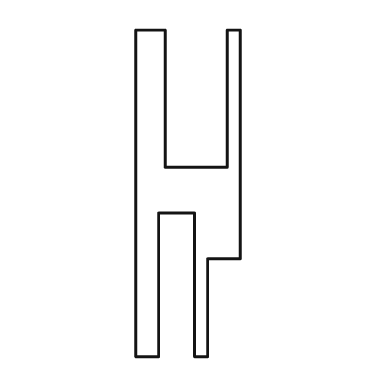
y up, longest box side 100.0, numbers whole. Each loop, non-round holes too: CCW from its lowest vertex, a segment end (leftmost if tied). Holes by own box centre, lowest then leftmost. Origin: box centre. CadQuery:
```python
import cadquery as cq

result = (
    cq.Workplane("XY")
    .moveTo(-16.0, -50.0)
    .lineTo(-9.0, -50.0)
    .lineTo(-9.0, -6.0)
    .lineTo(2.0, -6.0)
    .lineTo(2.0, -50.0)
    .lineTo(6.0, -50.0)
    .lineTo(6.0, -20.0)
    .lineTo(16.0, -20.0)
    .lineTo(16.0, 50.0)
    .lineTo(12.0, 50.0)
    .lineTo(12.0, 8.0)
    .lineTo(-7.0, 8.0)
    .lineTo(-7.0, 50.0)
    .lineTo(-16.0, 50.0)
    .close()
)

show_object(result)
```